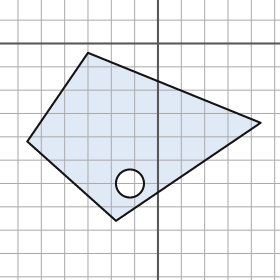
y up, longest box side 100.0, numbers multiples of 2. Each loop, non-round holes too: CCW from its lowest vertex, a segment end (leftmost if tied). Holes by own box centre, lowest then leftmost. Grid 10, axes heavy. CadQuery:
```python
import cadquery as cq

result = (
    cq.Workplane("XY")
    .moveTo(-18.0, -76.0)
    .lineTo(44.0, -34.0)
    .lineTo(-30.0, -4.0)
    .lineTo(-56.0, -42.0)
    .close()
    .moveTo(-12.0, -60.0)
    .circle(6.0)
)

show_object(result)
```